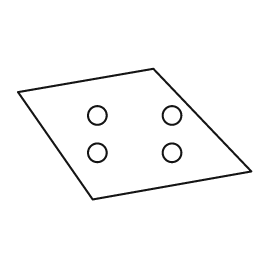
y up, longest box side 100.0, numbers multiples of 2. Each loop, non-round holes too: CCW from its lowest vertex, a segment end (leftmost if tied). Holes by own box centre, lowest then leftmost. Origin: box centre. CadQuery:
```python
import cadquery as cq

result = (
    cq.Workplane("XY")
    .moveTo(-18.0, -28.0)
    .lineTo(50.0, -16.0)
    .lineTo(8.0, 28.0)
    .lineTo(-50.0, 18.0)
    .close()
    .moveTo(-16.0, -8.0)
    .circle(4.0)
    .moveTo(16.0, -8.0)
    .circle(4.0)
    .moveTo(-16.0, 8.0)
    .circle(4.0)
    .moveTo(16.0, 8.0)
    .circle(4.0)
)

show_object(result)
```